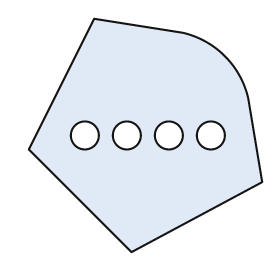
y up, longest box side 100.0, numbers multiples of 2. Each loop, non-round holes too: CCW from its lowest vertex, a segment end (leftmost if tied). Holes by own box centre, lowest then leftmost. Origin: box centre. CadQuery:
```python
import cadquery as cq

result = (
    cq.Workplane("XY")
    .moveTo(-6.0, -50.0)
    .lineTo(50.0, -20.0)
    .lineTo(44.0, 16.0)
    .threePointArc((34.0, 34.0), (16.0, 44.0))
    .lineTo(-22.0, 50.0)
    .lineTo(-50.0, -6.0)
    .close()
    .moveTo(-26.0, 0.0)
    .circle(6.0)
    .moveTo(-8.0, 0.0)
    .circle(6.0)
    .moveTo(10.0, 0.0)
    .circle(6.0)
    .moveTo(28.0, 0.0)
    .circle(6.0)
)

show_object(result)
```